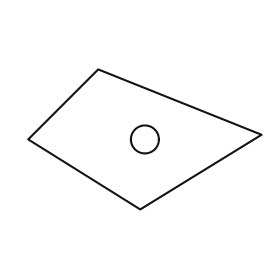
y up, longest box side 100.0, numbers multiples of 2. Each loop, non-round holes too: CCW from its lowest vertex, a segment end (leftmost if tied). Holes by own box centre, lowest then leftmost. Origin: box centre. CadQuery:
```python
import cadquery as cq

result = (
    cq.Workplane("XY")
    .moveTo(-2.0, -30.0)
    .lineTo(50.0, 2.0)
    .lineTo(-20.0, 30.0)
    .lineTo(-50.0, 0.0)
    .close()
    .moveTo(0.0, 0.0)
    .circle(6.0)
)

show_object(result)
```